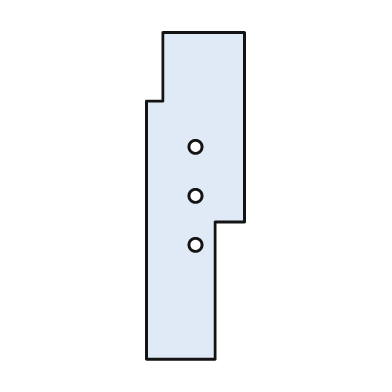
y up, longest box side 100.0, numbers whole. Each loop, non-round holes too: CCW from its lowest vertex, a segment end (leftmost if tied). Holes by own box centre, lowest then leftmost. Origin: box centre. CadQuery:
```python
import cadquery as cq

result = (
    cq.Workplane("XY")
    .moveTo(-15.0, -50.0)
    .lineTo(6.0, -50.0)
    .lineTo(6.0, -8.0)
    .lineTo(15.0, -8.0)
    .lineTo(15.0, 50.0)
    .lineTo(-10.0, 50.0)
    .lineTo(-10.0, 29.0)
    .lineTo(-15.0, 29.0)
    .close()
    .moveTo(0.0, -15.0)
    .circle(2.0)
    .moveTo(0.0, 0.0)
    .circle(2.0)
    .moveTo(0.0, 15.0)
    .circle(2.0)
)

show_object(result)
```